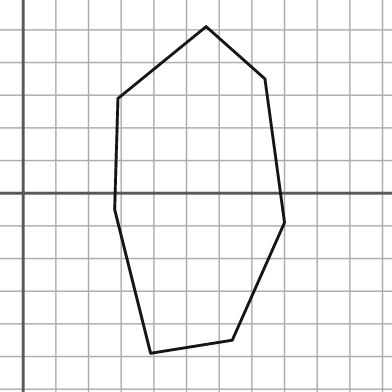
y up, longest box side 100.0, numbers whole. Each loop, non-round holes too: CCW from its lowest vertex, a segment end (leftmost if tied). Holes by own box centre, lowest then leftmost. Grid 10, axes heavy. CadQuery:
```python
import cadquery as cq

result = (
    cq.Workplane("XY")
    .moveTo(39.0, -49.0)
    .lineTo(64.0, -45.0)
    .lineTo(80.0, -9.0)
    .lineTo(74.0, 35.0)
    .lineTo(56.0, 51.0)
    .lineTo(29.0, 29.0)
    .lineTo(28.0, -5.0)
    .close()
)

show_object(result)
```